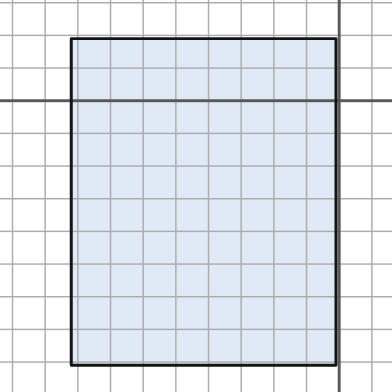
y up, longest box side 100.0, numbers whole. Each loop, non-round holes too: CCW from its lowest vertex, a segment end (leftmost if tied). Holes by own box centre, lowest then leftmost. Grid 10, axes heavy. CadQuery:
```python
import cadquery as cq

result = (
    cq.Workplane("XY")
    .moveTo(-82.0, -81.0)
    .lineTo(-1.0, -81.0)
    .lineTo(-1.0, 19.0)
    .lineTo(-82.0, 19.0)
    .close()
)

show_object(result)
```